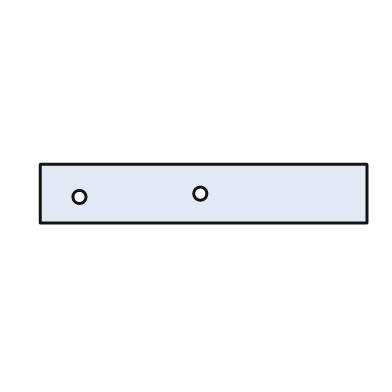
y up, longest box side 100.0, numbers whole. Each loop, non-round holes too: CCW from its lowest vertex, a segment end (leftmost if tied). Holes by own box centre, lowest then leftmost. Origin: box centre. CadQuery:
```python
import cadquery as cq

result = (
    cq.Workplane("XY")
    .moveTo(-50.0, -9.0)
    .lineTo(50.0, -9.0)
    .lineTo(50.0, 9.0)
    .lineTo(-50.0, 9.0)
    .close()
    .moveTo(-38.0, -1.0)
    .circle(2.0)
    .moveTo(-1.0, 0.0)
    .circle(2.0)
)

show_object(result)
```